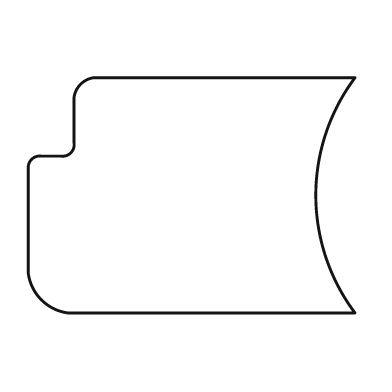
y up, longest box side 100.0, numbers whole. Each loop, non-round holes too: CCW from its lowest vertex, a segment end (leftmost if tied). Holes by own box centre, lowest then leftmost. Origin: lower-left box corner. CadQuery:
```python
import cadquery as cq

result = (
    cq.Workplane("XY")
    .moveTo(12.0, 0.0)
    .lineTo(100.0, 0.0)
    .threePointArc((88.0, 36.0), (100.0, 72.0))
    .lineTo(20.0, 72.0)
    .threePointArc((16.0, 70.0), (14.0, 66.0))
    .lineTo(14.0, 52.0)
    .threePointArc((13.0, 49.0), (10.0, 48.0))
    .lineTo(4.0, 48.0)
    .threePointArc((1.0, 47.0), (0.0, 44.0))
    .lineTo(0.0, 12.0)
    .threePointArc((4.0, 4.0), (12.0, 0.0))
    .close()
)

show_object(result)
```